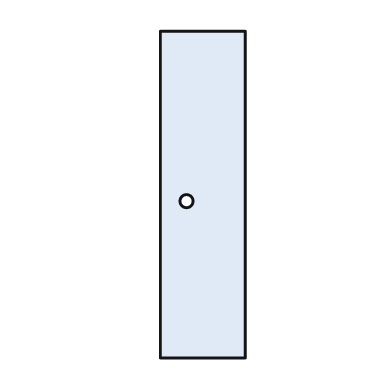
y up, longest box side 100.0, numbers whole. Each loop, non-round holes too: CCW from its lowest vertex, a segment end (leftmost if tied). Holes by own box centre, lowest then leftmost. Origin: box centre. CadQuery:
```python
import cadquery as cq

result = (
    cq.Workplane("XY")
    .moveTo(-13.0, -50.0)
    .lineTo(13.0, -50.0)
    .lineTo(13.0, 50.0)
    .lineTo(-13.0, 50.0)
    .close()
    .moveTo(-5.0, -2.0)
    .circle(2.0)
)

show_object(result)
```